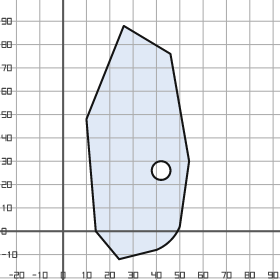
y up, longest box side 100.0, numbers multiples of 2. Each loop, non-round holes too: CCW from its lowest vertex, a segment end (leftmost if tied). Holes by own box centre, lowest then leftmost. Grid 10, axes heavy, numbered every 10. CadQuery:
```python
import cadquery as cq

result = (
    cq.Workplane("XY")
    .moveTo(24.0, -12.0)
    .lineTo(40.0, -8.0)
    .threePointArc((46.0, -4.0), (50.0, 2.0))
    .lineTo(54.0, 30.0)
    .lineTo(46.0, 76.0)
    .lineTo(26.0, 88.0)
    .lineTo(10.0, 48.0)
    .lineTo(14.0, 0.0)
    .close()
    .moveTo(42.0, 26.0)
    .circle(4.0)
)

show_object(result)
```